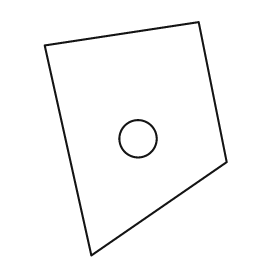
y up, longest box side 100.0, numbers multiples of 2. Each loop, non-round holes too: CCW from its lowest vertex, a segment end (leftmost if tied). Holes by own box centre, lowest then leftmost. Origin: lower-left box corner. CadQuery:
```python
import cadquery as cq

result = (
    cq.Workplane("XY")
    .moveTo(20.0, 0.0)
    .lineTo(78.0, 40.0)
    .lineTo(66.0, 100.0)
    .lineTo(0.0, 90.0)
    .close()
    .moveTo(40.0, 50.0)
    .circle(8.0)
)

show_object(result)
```